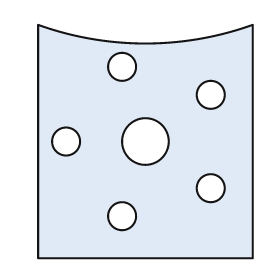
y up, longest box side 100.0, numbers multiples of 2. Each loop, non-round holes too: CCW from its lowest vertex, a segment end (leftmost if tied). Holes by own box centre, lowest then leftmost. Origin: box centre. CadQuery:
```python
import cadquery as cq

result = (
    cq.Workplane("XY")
    .moveTo(-46.0, -50.0)
    .lineTo(46.0, -50.0)
    .lineTo(46.0, 50.0)
    .threePointArc((0.0, 42.0), (-46.0, 50.0))
    .close()
    .moveTo(-10.0, -32.0)
    .circle(6.0)
    .moveTo(28.0, -20.0)
    .circle(6.0)
    .moveTo(-34.0, 0.0)
    .circle(6.0)
    .moveTo(0.0, 0.0)
    .circle(10.0)
    .moveTo(28.0, 20.0)
    .circle(6.0)
    .moveTo(-10.0, 32.0)
    .circle(6.0)
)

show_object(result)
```